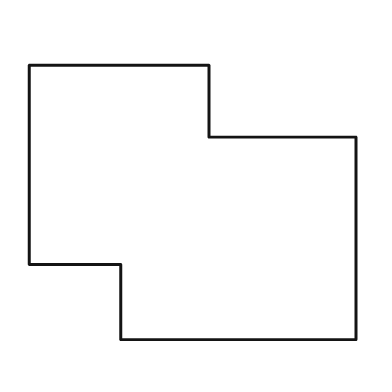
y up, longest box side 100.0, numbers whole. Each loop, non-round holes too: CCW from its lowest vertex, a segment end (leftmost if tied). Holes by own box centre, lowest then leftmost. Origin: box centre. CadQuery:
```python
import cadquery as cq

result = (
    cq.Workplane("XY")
    .moveTo(-22.0, -42.0)
    .lineTo(50.0, -42.0)
    .lineTo(50.0, 20.0)
    .lineTo(5.0, 20.0)
    .lineTo(5.0, 42.0)
    .lineTo(-50.0, 42.0)
    .lineTo(-50.0, -19.0)
    .lineTo(-22.0, -19.0)
    .close()
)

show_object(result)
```